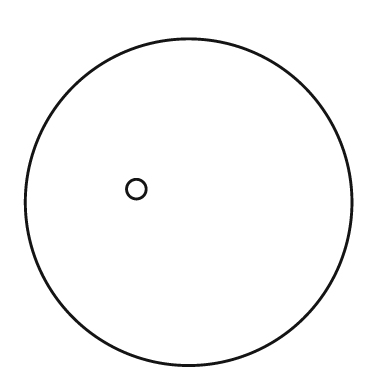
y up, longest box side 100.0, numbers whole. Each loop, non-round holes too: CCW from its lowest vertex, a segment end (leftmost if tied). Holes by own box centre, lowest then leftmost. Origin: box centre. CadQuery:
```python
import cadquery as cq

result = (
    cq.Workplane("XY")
    .moveTo(0.0, 0.0)
    .circle(50.0)
    .moveTo(-16.0, 4.0)
    .circle(3.0)
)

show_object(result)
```